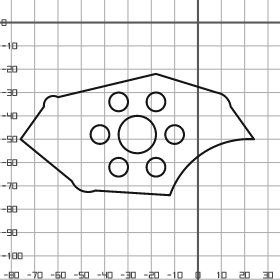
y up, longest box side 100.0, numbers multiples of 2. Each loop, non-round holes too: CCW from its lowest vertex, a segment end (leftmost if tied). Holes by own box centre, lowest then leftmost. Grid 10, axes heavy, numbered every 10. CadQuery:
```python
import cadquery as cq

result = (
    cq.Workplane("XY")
    .moveTo(-12.0, -74.0)
    .threePointArc((2.0, -56.0), (24.0, -50.0))
    .lineTo(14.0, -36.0)
    .threePointArc((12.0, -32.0), (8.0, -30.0))
    .lineTo(-18.0, -22.0)
    .lineTo(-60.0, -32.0)
    .threePointArc((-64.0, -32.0), (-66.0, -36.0))
    .lineTo(-76.0, -50.0)
    .lineTo(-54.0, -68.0)
    .threePointArc((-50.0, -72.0), (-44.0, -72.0))
    .close()
    .moveTo(-34.0, -62.0)
    .circle(4.0)
    .moveTo(-18.0, -62.0)
    .circle(4.0)
    .moveTo(-42.0, -48.0)
    .circle(4.0)
    .moveTo(-26.0, -48.0)
    .circle(8.0)
    .moveTo(-10.0, -48.0)
    .circle(4.0)
    .moveTo(-34.0, -34.0)
    .circle(4.0)
    .moveTo(-18.0, -34.0)
    .circle(4.0)
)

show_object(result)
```